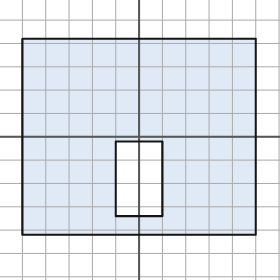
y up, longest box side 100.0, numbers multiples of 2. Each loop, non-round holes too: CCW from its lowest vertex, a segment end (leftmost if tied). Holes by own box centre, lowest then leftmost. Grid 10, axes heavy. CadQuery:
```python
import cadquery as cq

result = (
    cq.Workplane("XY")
    .moveTo(-50.0, -42.0)
    .lineTo(50.0, -42.0)
    .lineTo(50.0, 42.0)
    .lineTo(-50.0, 42.0)
    .close()
    .moveTo(-10.0, -34.0)
    .lineTo(10.0, -34.0)
    .lineTo(10.0, -2.0)
    .lineTo(-10.0, -2.0)
    .close()
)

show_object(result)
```